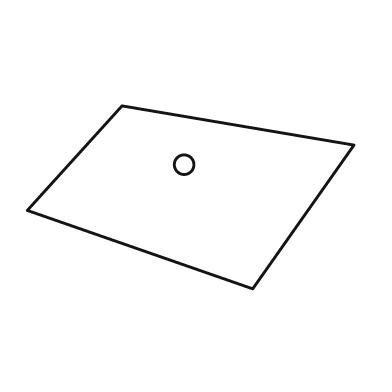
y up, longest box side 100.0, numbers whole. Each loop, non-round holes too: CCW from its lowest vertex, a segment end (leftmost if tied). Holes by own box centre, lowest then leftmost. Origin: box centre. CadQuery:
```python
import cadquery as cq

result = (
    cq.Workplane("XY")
    .moveTo(19.0, -28.0)
    .lineTo(50.0, 16.0)
    .lineTo(-21.0, 28.0)
    .lineTo(-50.0, -4.0)
    .close()
    .moveTo(-2.0, 10.0)
    .circle(3.0)
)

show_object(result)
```